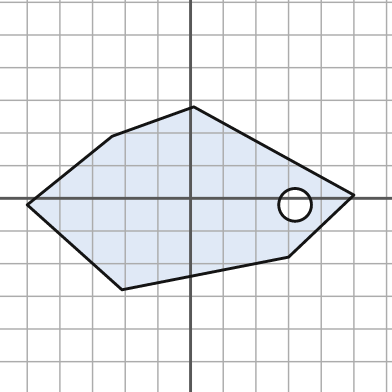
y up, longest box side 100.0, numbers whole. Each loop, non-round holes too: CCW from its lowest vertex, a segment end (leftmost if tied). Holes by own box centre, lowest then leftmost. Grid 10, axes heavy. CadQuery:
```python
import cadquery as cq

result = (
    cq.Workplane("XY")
    .moveTo(-21.0, -28.0)
    .lineTo(30.0, -18.0)
    .lineTo(50.0, 1.0)
    .lineTo(1.0, 28.0)
    .lineTo(-24.0, 19.0)
    .lineTo(-50.0, -2.0)
    .close()
    .moveTo(32.0, -2.0)
    .circle(5.0)
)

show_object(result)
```